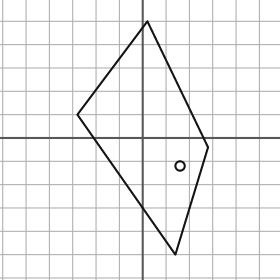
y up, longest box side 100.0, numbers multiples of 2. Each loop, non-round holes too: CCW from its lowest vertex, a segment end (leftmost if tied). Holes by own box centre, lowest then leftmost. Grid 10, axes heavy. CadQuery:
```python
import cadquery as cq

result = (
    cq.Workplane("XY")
    .moveTo(14.0, -50.0)
    .lineTo(28.0, -4.0)
    .lineTo(2.0, 50.0)
    .lineTo(-28.0, 10.0)
    .close()
    .moveTo(16.0, -12.0)
    .circle(2.0)
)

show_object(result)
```